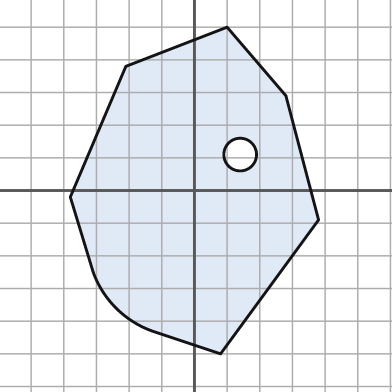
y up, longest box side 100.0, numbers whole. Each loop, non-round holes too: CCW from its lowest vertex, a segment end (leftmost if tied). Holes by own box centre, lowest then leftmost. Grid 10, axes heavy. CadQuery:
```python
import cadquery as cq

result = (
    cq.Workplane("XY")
    .moveTo(8.0, -50.0)
    .lineTo(38.0, -9.0)
    .lineTo(28.0, 29.0)
    .lineTo(10.0, 50.0)
    .lineTo(-21.0, 38.0)
    .lineTo(-38.0, -2.0)
    .lineTo(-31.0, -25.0)
    .threePointArc((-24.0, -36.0), (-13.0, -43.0))
    .close()
    .moveTo(14.0, 11.0)
    .circle(5.0)
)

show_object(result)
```